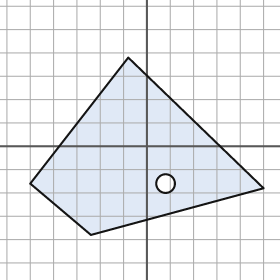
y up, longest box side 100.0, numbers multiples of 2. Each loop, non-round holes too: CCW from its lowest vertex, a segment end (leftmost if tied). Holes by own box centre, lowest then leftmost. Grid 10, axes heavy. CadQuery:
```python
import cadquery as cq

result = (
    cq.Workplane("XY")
    .moveTo(-24.0, -38.0)
    .lineTo(50.0, -18.0)
    .lineTo(-8.0, 38.0)
    .lineTo(-50.0, -16.0)
    .close()
    .moveTo(8.0, -16.0)
    .circle(4.0)
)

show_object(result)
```